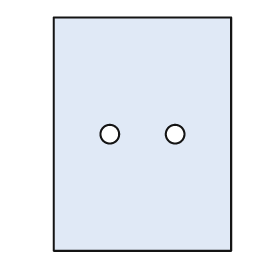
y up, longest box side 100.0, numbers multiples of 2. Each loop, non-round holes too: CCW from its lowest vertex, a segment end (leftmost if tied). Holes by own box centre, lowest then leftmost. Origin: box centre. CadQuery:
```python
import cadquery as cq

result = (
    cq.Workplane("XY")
    .moveTo(-38.0, -50.0)
    .lineTo(38.0, -50.0)
    .lineTo(38.0, 50.0)
    .lineTo(-38.0, 50.0)
    .close()
    .moveTo(-14.0, 0.0)
    .circle(4.0)
    .moveTo(14.0, 0.0)
    .circle(4.0)
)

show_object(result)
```